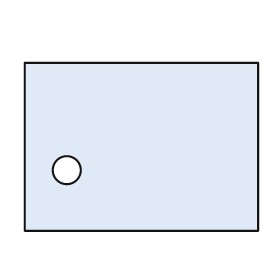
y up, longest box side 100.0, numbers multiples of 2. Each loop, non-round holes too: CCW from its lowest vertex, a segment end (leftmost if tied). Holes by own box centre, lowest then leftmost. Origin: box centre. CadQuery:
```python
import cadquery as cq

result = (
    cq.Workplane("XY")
    .moveTo(-50.0, -36.0)
    .lineTo(50.0, -36.0)
    .lineTo(50.0, 36.0)
    .lineTo(-50.0, 36.0)
    .close()
    .moveTo(-32.0, -10.0)
    .circle(6.0)
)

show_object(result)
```